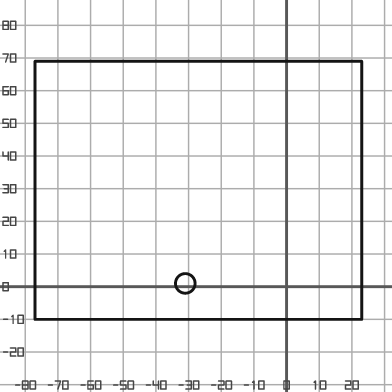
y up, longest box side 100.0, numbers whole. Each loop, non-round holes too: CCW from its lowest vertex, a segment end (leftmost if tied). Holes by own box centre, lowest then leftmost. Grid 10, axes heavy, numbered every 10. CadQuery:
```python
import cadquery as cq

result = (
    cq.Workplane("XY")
    .moveTo(-77.0, -10.0)
    .lineTo(23.0, -10.0)
    .lineTo(23.0, 69.0)
    .lineTo(-77.0, 69.0)
    .close()
    .moveTo(-31.0, 1.0)
    .circle(3.0)
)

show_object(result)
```